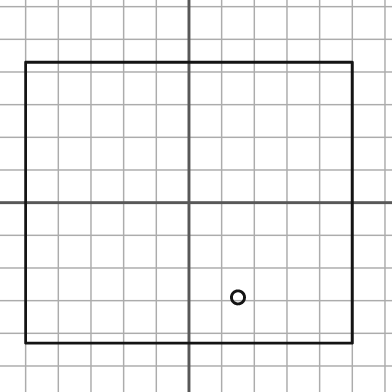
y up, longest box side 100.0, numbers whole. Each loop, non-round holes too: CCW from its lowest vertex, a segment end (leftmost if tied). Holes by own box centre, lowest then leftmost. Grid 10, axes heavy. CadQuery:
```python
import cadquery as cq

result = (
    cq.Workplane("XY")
    .moveTo(-50.0, -43.0)
    .lineTo(50.0, -43.0)
    .lineTo(50.0, 43.0)
    .lineTo(-50.0, 43.0)
    .close()
    .moveTo(15.0, -29.0)
    .circle(2.0)
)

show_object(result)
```